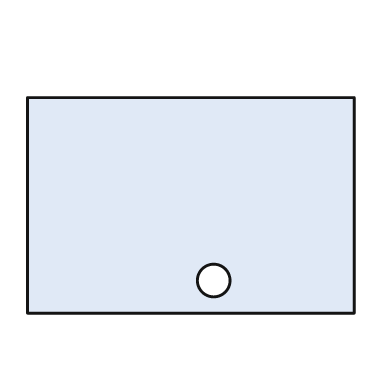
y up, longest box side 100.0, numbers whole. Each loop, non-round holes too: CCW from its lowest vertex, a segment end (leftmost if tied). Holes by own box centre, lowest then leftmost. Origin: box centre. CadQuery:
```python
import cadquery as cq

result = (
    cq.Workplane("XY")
    .moveTo(-50.0, -33.0)
    .lineTo(50.0, -33.0)
    .lineTo(50.0, 33.0)
    .lineTo(-50.0, 33.0)
    .close()
    .moveTo(7.0, -23.0)
    .circle(5.0)
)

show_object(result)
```